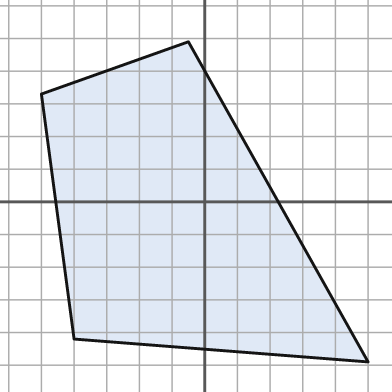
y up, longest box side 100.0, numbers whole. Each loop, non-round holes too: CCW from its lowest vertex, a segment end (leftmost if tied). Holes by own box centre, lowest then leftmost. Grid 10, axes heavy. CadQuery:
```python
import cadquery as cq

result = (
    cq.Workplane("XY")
    .moveTo(50.0, -49.0)
    .lineTo(-5.0, 49.0)
    .lineTo(-50.0, 33.0)
    .lineTo(-40.0, -42.0)
    .close()
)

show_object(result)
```